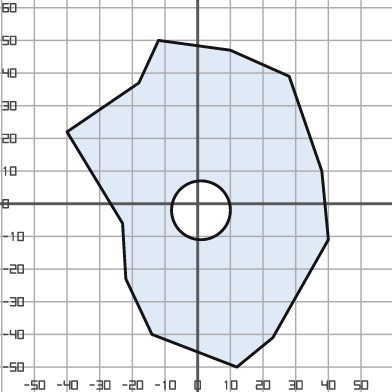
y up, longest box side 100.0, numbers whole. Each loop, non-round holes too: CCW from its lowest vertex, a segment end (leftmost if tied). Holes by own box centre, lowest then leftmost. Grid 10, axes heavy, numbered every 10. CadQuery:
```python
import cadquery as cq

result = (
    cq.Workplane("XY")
    .moveTo(12.0, -50.0)
    .lineTo(23.0, -41.0)
    .lineTo(40.0, -11.0)
    .lineTo(38.0, 10.0)
    .lineTo(28.0, 39.0)
    .lineTo(10.0, 47.0)
    .lineTo(-12.0, 50.0)
    .lineTo(-18.0, 37.0)
    .lineTo(-40.0, 22.0)
    .lineTo(-23.0, -6.0)
    .lineTo(-22.0, -23.0)
    .lineTo(-14.0, -40.0)
    .close()
    .moveTo(1.0, -2.0)
    .circle(9.0)
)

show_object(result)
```